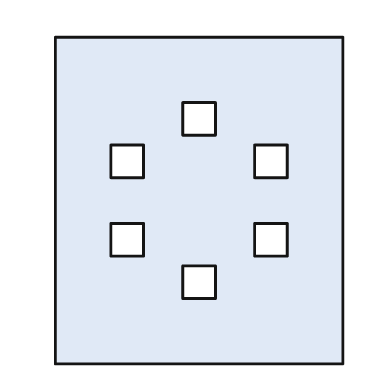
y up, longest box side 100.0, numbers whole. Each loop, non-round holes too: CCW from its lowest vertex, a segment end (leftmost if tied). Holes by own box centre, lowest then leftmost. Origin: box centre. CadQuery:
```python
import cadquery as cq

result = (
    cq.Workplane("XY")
    .moveTo(-44.0, -50.0)
    .lineTo(44.0, -50.0)
    .lineTo(44.0, 50.0)
    .lineTo(-44.0, 50.0)
    .close()
    .moveTo(-5.0, -30.0)
    .lineTo(5.0, -30.0)
    .lineTo(5.0, -20.0)
    .lineTo(-5.0, -20.0)
    .close()
    .moveTo(-27.0, -17.0)
    .lineTo(-17.0, -17.0)
    .lineTo(-17.0, -7.0)
    .lineTo(-27.0, -7.0)
    .close()
    .moveTo(17.0, -17.0)
    .lineTo(27.0, -17.0)
    .lineTo(27.0, -7.0)
    .lineTo(17.0, -7.0)
    .close()
    .moveTo(-27.0, 7.0)
    .lineTo(-17.0, 7.0)
    .lineTo(-17.0, 17.0)
    .lineTo(-27.0, 17.0)
    .close()
    .moveTo(17.0, 7.0)
    .lineTo(27.0, 7.0)
    .lineTo(27.0, 17.0)
    .lineTo(17.0, 17.0)
    .close()
    .moveTo(-5.0, 20.0)
    .lineTo(5.0, 20.0)
    .lineTo(5.0, 30.0)
    .lineTo(-5.0, 30.0)
    .close()
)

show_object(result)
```